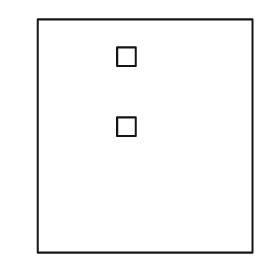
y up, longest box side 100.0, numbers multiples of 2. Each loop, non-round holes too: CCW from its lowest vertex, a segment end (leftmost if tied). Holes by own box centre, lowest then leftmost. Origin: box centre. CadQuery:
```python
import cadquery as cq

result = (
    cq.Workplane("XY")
    .moveTo(-46.0, -50.0)
    .lineTo(46.0, -50.0)
    .lineTo(46.0, 50.0)
    .lineTo(-46.0, 50.0)
    .close()
    .moveTo(-12.0, 0.0)
    .lineTo(-4.0, 0.0)
    .lineTo(-4.0, 8.0)
    .lineTo(-12.0, 8.0)
    .close()
    .moveTo(-12.0, 30.0)
    .lineTo(-4.0, 30.0)
    .lineTo(-4.0, 38.0)
    .lineTo(-12.0, 38.0)
    .close()
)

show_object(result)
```